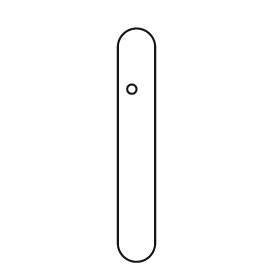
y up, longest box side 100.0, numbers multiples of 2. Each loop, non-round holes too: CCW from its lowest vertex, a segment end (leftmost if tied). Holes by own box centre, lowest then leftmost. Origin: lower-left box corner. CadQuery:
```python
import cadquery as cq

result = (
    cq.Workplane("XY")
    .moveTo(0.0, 8.0)
    .threePointArc((8.0, 0.0), (16.0, 8.0))
    .lineTo(16.0, 92.0)
    .threePointArc((8.0, 100.0), (0.0, 92.0))
    .close()
    .moveTo(6.0, 74.0)
    .circle(2.0)
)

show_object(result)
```